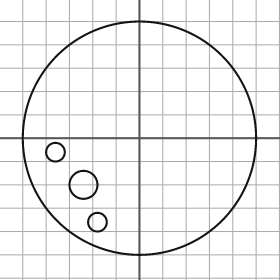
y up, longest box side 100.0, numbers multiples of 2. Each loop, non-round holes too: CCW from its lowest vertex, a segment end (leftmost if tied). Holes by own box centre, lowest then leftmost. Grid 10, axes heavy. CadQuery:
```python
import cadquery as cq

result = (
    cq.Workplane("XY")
    .moveTo(0.0, 0.0)
    .circle(50.0)
    .moveTo(-18.0, -36.0)
    .circle(4.0)
    .moveTo(-24.0, -20.0)
    .circle(6.0)
    .moveTo(-36.0, -6.0)
    .circle(4.0)
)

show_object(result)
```